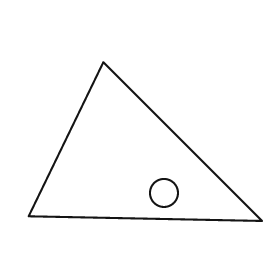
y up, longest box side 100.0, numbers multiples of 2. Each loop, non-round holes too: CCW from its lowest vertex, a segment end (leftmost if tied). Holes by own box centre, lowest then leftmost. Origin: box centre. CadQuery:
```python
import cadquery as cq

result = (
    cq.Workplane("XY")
    .moveTo(50.0, -34.0)
    .lineTo(-18.0, 34.0)
    .lineTo(-50.0, -32.0)
    .close()
    .moveTo(8.0, -22.0)
    .circle(6.0)
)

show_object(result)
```